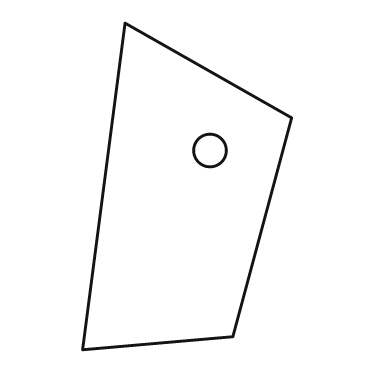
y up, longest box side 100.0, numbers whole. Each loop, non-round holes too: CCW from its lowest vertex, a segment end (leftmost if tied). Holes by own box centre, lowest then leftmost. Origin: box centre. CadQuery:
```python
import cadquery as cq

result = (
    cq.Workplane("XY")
    .moveTo(-32.0, -50.0)
    .lineTo(14.0, -46.0)
    .lineTo(32.0, 21.0)
    .lineTo(-19.0, 50.0)
    .close()
    .moveTo(7.0, 11.0)
    .circle(5.0)
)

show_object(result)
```